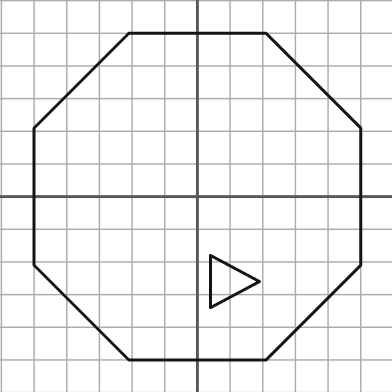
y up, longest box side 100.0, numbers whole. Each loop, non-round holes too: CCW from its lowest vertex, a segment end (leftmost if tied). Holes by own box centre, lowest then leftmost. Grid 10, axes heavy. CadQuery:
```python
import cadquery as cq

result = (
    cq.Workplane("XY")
    .moveTo(-21.0, -50.0)
    .lineTo(21.0, -50.0)
    .lineTo(50.0, -21.0)
    .lineTo(50.0, 21.0)
    .lineTo(21.0, 50.0)
    .lineTo(-21.0, 50.0)
    .lineTo(-50.0, 21.0)
    .lineTo(-50.0, -21.0)
    .close()
    .moveTo(4.0, -34.0)
    .lineTo(19.0, -26.0)
    .lineTo(4.0, -18.0)
    .close()
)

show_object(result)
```